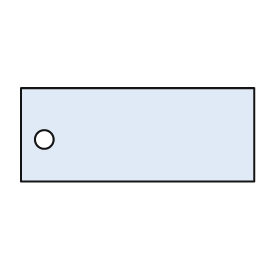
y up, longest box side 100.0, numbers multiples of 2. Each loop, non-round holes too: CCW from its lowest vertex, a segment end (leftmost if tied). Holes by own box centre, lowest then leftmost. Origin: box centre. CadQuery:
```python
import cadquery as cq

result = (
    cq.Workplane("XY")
    .moveTo(-50.0, -20.0)
    .lineTo(50.0, -20.0)
    .lineTo(50.0, 20.0)
    .lineTo(-50.0, 20.0)
    .close()
    .moveTo(-40.0, -2.0)
    .circle(4.0)
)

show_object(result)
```